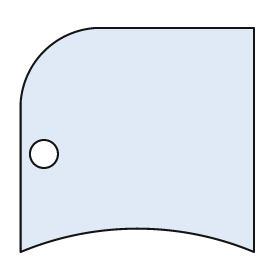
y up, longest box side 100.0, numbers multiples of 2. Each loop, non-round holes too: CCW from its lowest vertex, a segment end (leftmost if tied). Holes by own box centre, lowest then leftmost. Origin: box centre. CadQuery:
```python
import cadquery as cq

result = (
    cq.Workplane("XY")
    .moveTo(-50.0, -48.0)
    .threePointArc((0.0, -38.0), (50.0, -48.0))
    .lineTo(50.0, 48.0)
    .lineTo(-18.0, 48.0)
    .threePointArc((-40.0, 38.0), (-50.0, 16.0))
    .close()
    .moveTo(-40.0, -6.0)
    .circle(6.0)
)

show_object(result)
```